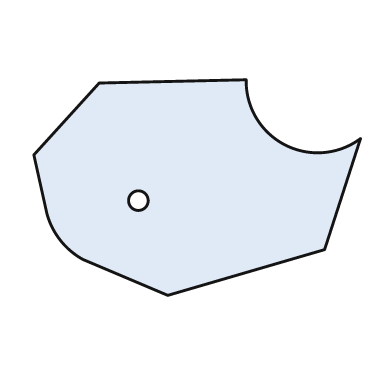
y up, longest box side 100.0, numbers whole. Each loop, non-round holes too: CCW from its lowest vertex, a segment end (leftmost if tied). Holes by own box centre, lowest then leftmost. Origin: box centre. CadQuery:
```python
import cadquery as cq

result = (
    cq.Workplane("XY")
    .moveTo(-9.0, -33.0)
    .lineTo(39.0, -19.0)
    .lineTo(50.0, 15.0)
    .threePointArc((27.0, 13.0), (15.0, 33.0))
    .lineTo(-30.0, 32.0)
    .lineTo(-50.0, 10.0)
    .lineTo(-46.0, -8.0)
    .threePointArc((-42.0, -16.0), (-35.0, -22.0))
    .close()
    .moveTo(-18.0, -4.0)
    .circle(3.0)
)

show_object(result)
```